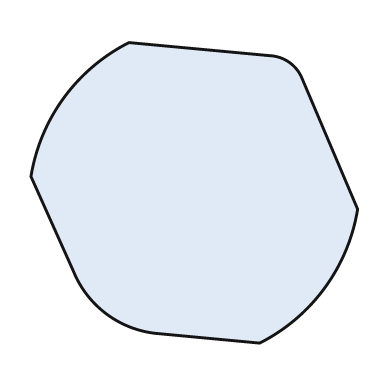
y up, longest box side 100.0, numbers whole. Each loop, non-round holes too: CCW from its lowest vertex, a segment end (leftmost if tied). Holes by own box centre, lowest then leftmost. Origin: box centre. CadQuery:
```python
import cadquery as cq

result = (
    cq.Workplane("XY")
    .moveTo(20.0, -46.0)
    .threePointArc((40.0, -29.0), (50.0, -5.0))
    .lineTo(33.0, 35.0)
    .threePointArc((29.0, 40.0), (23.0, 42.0))
    .lineTo(-20.0, 46.0)
    .threePointArc((-40.0, 29.0), (-50.0, 5.0))
    .lineTo(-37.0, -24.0)
    .threePointArc((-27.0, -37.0), (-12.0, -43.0))
    .close()
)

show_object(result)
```